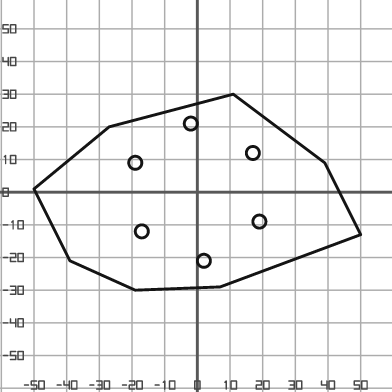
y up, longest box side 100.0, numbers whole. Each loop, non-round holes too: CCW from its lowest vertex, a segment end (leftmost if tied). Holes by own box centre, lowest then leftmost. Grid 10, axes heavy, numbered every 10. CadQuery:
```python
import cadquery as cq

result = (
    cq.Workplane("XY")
    .moveTo(-19.0, -30.0)
    .lineTo(7.0, -29.0)
    .lineTo(50.0, -13.0)
    .lineTo(39.0, 9.0)
    .lineTo(11.0, 30.0)
    .lineTo(-27.0, 20.0)
    .lineTo(-50.0, 1.0)
    .lineTo(-39.0, -21.0)
    .close()
    .moveTo(2.0, -21.0)
    .circle(2.0)
    .moveTo(-17.0, -12.0)
    .circle(2.0)
    .moveTo(19.0, -9.0)
    .circle(2.0)
    .moveTo(-19.0, 9.0)
    .circle(2.0)
    .moveTo(17.0, 12.0)
    .circle(2.0)
    .moveTo(-2.0, 21.0)
    .circle(2.0)
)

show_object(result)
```